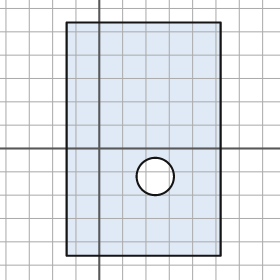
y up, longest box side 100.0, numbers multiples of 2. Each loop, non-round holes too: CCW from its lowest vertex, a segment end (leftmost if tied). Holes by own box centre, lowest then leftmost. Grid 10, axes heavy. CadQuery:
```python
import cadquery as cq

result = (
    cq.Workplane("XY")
    .moveTo(-14.0, -46.0)
    .lineTo(52.0, -46.0)
    .lineTo(52.0, 54.0)
    .lineTo(-14.0, 54.0)
    .close()
    .moveTo(24.0, -12.0)
    .circle(8.0)
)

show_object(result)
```